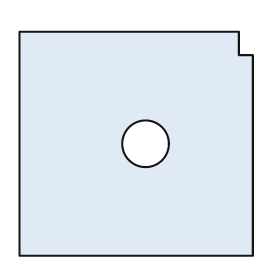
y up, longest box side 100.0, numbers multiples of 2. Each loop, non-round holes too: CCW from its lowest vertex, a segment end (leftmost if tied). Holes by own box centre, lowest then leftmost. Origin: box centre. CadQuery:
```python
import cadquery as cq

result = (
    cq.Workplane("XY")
    .moveTo(-50.0, -48.0)
    .lineTo(50.0, -48.0)
    .lineTo(50.0, 38.0)
    .lineTo(44.0, 38.0)
    .lineTo(44.0, 48.0)
    .lineTo(-50.0, 48.0)
    .close()
    .moveTo(4.0, 0.0)
    .circle(10.0)
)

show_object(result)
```